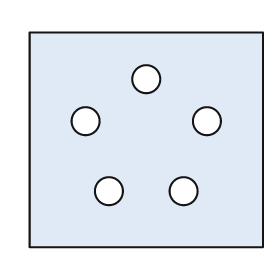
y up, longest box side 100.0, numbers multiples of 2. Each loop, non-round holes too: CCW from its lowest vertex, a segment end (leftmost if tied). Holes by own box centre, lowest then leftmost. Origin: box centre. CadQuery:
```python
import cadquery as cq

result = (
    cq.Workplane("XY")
    .moveTo(-50.0, -46.0)
    .lineTo(50.0, -46.0)
    .lineTo(50.0, 46.0)
    .lineTo(-50.0, 46.0)
    .close()
    .moveTo(-16.0, -22.0)
    .circle(6.0)
    .moveTo(16.0, -22.0)
    .circle(6.0)
    .moveTo(-26.0, 8.0)
    .circle(6.0)
    .moveTo(26.0, 8.0)
    .circle(6.0)
    .moveTo(0.0, 26.0)
    .circle(6.0)
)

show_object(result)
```